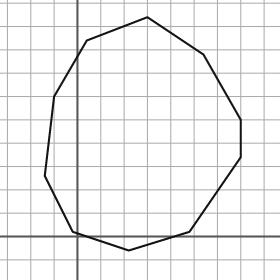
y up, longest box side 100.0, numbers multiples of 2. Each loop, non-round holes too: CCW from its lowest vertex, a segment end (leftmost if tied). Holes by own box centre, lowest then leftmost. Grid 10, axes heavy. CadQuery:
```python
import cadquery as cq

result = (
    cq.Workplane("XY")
    .moveTo(22.0, -6.0)
    .lineTo(48.0, 2.0)
    .lineTo(70.0, 34.0)
    .lineTo(70.0, 50.0)
    .lineTo(54.0, 78.0)
    .lineTo(30.0, 94.0)
    .lineTo(4.0, 84.0)
    .lineTo(-10.0, 60.0)
    .lineTo(-14.0, 26.0)
    .lineTo(-2.0, 2.0)
    .close()
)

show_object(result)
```